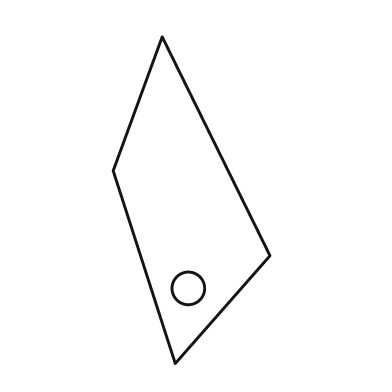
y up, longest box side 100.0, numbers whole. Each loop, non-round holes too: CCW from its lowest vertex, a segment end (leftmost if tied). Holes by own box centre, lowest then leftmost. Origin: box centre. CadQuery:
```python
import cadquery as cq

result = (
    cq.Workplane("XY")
    .moveTo(-5.0, -50.0)
    .lineTo(24.0, -17.0)
    .lineTo(-9.0, 50.0)
    .lineTo(-24.0, 9.0)
    .close()
    .moveTo(-1.0, -27.0)
    .circle(5.0)
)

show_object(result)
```